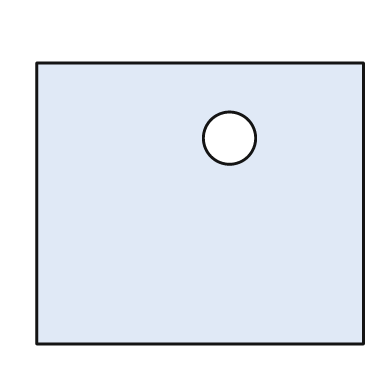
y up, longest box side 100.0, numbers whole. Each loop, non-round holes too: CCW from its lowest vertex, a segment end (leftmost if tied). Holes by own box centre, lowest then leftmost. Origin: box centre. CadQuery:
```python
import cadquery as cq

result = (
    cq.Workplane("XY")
    .moveTo(-50.0, -43.0)
    .lineTo(50.0, -43.0)
    .lineTo(50.0, 43.0)
    .lineTo(-50.0, 43.0)
    .close()
    .moveTo(9.0, 20.0)
    .circle(8.0)
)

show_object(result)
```